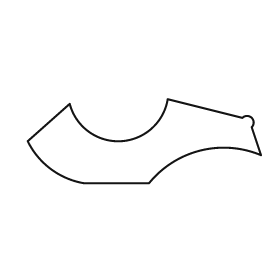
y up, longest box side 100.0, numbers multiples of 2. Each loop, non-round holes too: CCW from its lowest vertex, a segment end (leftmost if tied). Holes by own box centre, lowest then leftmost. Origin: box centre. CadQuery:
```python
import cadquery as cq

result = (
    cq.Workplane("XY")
    .moveTo(-26.0, -18.0)
    .lineTo(2.0, -18.0)
    .threePointArc((24.0, -4.0), (50.0, -6.0))
    .lineTo(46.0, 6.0)
    .threePointArc((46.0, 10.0), (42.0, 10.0))
    .lineTo(10.0, 18.0)
    .threePointArc((-10.0, 0.0), (-32.0, 16.0))
    .lineTo(-50.0, 0.0)
    .threePointArc((-40.0, -12.0), (-26.0, -18.0))
    .close()
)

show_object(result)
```